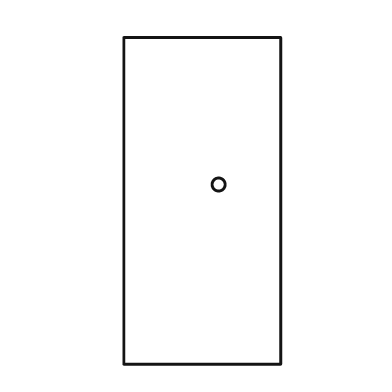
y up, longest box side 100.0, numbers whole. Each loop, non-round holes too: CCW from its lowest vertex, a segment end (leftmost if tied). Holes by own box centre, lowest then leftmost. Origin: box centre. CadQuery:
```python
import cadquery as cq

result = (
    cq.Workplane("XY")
    .moveTo(-24.0, -50.0)
    .lineTo(24.0, -50.0)
    .lineTo(24.0, 50.0)
    .lineTo(-24.0, 50.0)
    .close()
    .moveTo(5.0, 5.0)
    .circle(2.0)
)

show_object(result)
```